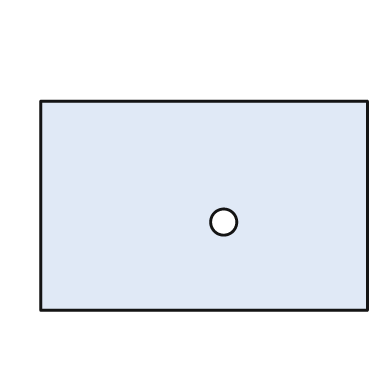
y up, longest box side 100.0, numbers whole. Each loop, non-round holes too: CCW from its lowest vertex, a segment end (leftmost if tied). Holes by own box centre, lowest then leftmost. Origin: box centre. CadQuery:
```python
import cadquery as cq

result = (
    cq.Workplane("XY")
    .moveTo(-50.0, -32.0)
    .lineTo(50.0, -32.0)
    .lineTo(50.0, 32.0)
    .lineTo(-50.0, 32.0)
    .close()
    .moveTo(6.0, -5.0)
    .circle(4.0)
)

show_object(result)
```